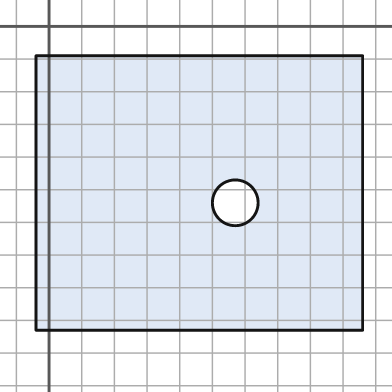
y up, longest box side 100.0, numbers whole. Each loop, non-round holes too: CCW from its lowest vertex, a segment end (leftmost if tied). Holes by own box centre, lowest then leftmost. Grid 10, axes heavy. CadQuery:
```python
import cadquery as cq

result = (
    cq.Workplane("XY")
    .moveTo(-4.0, -93.0)
    .lineTo(96.0, -93.0)
    .lineTo(96.0, -9.0)
    .lineTo(-4.0, -9.0)
    .close()
    .moveTo(57.0, -54.0)
    .circle(7.0)
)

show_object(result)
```